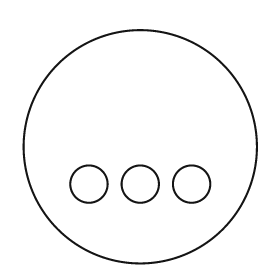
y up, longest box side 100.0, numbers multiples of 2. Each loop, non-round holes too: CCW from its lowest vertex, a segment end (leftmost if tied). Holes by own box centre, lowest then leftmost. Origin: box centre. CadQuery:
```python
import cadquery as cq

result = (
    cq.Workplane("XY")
    .moveTo(0.0, 0.0)
    .circle(50.0)
    .moveTo(-22.0, -16.0)
    .circle(8.0)
    .moveTo(0.0, -16.0)
    .circle(8.0)
    .moveTo(22.0, -16.0)
    .circle(8.0)
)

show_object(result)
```